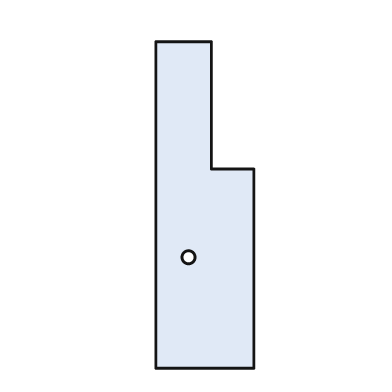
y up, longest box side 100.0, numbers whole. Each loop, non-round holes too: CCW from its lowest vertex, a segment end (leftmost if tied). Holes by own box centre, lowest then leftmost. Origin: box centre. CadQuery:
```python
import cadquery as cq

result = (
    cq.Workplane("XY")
    .moveTo(-15.0, -50.0)
    .lineTo(15.0, -50.0)
    .lineTo(15.0, 11.0)
    .lineTo(2.0, 11.0)
    .lineTo(2.0, 50.0)
    .lineTo(-15.0, 50.0)
    .close()
    .moveTo(-5.0, -16.0)
    .circle(2.0)
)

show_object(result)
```